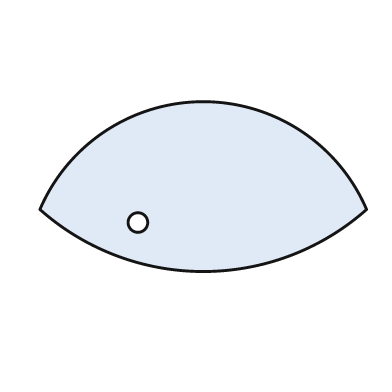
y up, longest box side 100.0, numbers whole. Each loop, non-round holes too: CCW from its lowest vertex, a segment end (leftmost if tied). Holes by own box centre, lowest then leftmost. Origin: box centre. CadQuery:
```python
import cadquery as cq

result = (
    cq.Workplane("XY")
    .moveTo(-50.0, -7.0)
    .threePointArc((0.0, -26.0), (50.0, -7.0))
    .threePointArc((0.0, 26.0), (-50.0, -7.0))
    .close()
    .moveTo(-20.0, -11.0)
    .circle(3.0)
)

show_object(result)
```